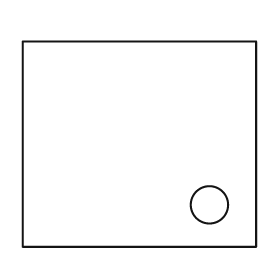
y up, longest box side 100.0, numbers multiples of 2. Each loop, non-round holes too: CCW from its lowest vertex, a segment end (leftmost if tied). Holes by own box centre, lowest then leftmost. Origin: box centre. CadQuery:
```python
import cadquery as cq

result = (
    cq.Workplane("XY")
    .moveTo(-50.0, -44.0)
    .lineTo(50.0, -44.0)
    .lineTo(50.0, 44.0)
    .lineTo(-50.0, 44.0)
    .close()
    .moveTo(30.0, -26.0)
    .circle(8.0)
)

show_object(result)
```